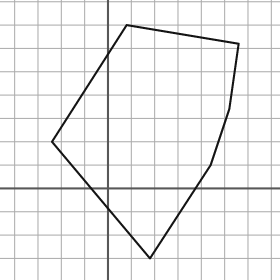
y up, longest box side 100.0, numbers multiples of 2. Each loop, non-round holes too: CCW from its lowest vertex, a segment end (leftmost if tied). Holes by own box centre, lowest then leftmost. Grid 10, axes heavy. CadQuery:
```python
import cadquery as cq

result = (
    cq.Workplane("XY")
    .moveTo(18.0, -30.0)
    .lineTo(44.0, 10.0)
    .lineTo(52.0, 34.0)
    .lineTo(56.0, 62.0)
    .lineTo(8.0, 70.0)
    .lineTo(-24.0, 20.0)
    .close()
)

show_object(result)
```